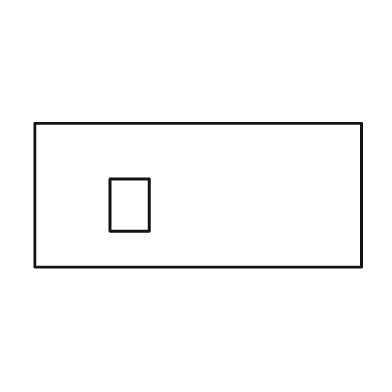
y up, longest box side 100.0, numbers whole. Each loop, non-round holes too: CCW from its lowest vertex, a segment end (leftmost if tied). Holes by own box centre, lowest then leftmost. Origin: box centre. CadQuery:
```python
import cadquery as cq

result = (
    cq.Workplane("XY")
    .moveTo(-50.0, -22.0)
    .lineTo(50.0, -22.0)
    .lineTo(50.0, 22.0)
    .lineTo(-50.0, 22.0)
    .close()
    .moveTo(-27.0, -11.0)
    .lineTo(-15.0, -11.0)
    .lineTo(-15.0, 5.0)
    .lineTo(-27.0, 5.0)
    .close()
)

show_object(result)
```